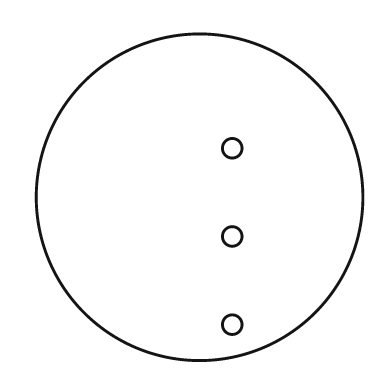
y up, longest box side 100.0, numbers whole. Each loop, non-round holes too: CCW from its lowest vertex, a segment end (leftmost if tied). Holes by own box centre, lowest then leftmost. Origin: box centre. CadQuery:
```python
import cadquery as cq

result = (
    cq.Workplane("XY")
    .moveTo(0.0, 0.0)
    .circle(50.0)
    .moveTo(10.0, -39.0)
    .circle(3.0)
    .moveTo(10.0, -12.0)
    .circle(3.0)
    .moveTo(10.0, 15.0)
    .circle(3.0)
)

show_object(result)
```